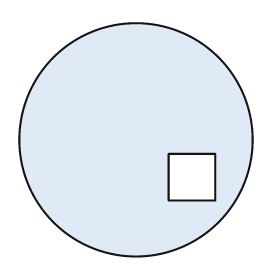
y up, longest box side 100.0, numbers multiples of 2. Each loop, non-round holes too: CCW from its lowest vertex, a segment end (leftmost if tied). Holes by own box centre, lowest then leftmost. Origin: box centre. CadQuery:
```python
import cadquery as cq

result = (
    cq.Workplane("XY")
    .moveTo(0.0, 0.0)
    .circle(50.0)
    .moveTo(14.0, -26.0)
    .lineTo(34.0, -26.0)
    .lineTo(34.0, -6.0)
    .lineTo(14.0, -6.0)
    .close()
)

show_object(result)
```